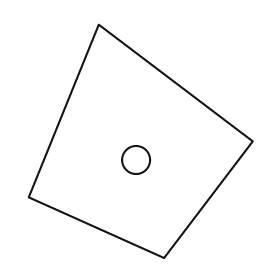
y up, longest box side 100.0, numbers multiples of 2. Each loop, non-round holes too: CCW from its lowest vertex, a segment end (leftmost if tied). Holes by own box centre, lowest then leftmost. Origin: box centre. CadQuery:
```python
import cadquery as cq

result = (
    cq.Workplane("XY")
    .moveTo(10.0, -50.0)
    .lineTo(48.0, 0.0)
    .lineTo(-18.0, 50.0)
    .lineTo(-48.0, -24.0)
    .close()
    .moveTo(-2.0, -8.0)
    .circle(6.0)
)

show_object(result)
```